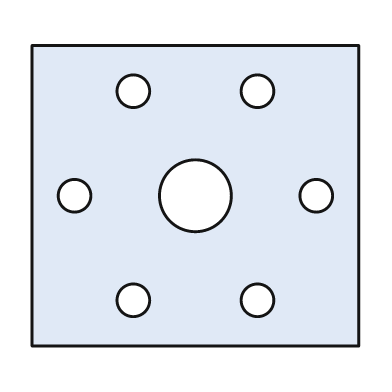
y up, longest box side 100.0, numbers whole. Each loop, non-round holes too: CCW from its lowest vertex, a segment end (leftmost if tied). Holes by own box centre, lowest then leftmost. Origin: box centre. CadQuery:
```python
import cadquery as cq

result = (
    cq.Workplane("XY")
    .moveTo(-50.0, -46.0)
    .lineTo(50.0, -46.0)
    .lineTo(50.0, 46.0)
    .lineTo(-50.0, 46.0)
    .close()
    .moveTo(-19.0, -32.0)
    .circle(5.0)
    .moveTo(19.0, -32.0)
    .circle(5.0)
    .moveTo(-37.0, 0.0)
    .circle(5.0)
    .moveTo(0.0, 0.0)
    .circle(11.0)
    .moveTo(37.0, 0.0)
    .circle(5.0)
    .moveTo(-19.0, 32.0)
    .circle(5.0)
    .moveTo(19.0, 32.0)
    .circle(5.0)
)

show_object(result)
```